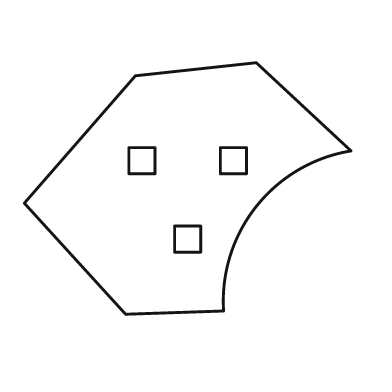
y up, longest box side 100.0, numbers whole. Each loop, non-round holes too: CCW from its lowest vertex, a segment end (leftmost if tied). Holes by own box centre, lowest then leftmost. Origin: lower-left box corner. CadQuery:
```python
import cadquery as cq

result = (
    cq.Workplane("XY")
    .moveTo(31.0, 0.0)
    .lineTo(61.0, 1.0)
    .threePointArc((71.0, 33.0), (100.0, 50.0))
    .lineTo(71.0, 77.0)
    .lineTo(34.0, 73.0)
    .lineTo(0.0, 34.0)
    .close()
    .moveTo(46.0, 19.0)
    .lineTo(54.0, 19.0)
    .lineTo(54.0, 27.0)
    .lineTo(46.0, 27.0)
    .close()
    .moveTo(32.0, 43.0)
    .lineTo(40.0, 43.0)
    .lineTo(40.0, 51.0)
    .lineTo(32.0, 51.0)
    .close()
    .moveTo(60.0, 43.0)
    .lineTo(68.0, 43.0)
    .lineTo(68.0, 51.0)
    .lineTo(60.0, 51.0)
    .close()
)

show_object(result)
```